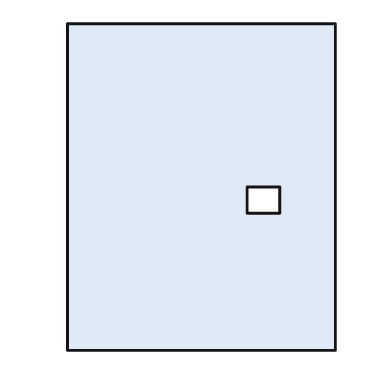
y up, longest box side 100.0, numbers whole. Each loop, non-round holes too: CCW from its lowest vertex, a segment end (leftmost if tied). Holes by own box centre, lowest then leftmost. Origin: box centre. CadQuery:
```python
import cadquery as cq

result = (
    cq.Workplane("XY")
    .moveTo(-41.0, -50.0)
    .lineTo(41.0, -50.0)
    .lineTo(41.0, 50.0)
    .lineTo(-41.0, 50.0)
    .close()
    .moveTo(14.0, -8.0)
    .lineTo(24.0, -8.0)
    .lineTo(24.0, 0.0)
    .lineTo(14.0, 0.0)
    .close()
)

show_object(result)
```